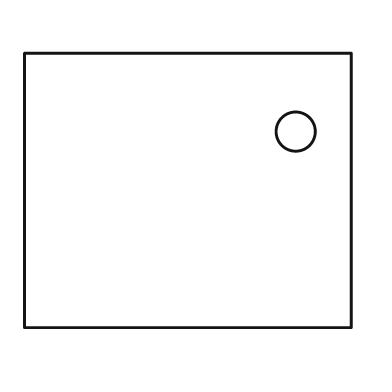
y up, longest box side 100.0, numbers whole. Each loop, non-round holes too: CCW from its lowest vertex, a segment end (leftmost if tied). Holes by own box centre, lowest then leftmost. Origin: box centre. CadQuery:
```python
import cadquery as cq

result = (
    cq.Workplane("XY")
    .moveTo(-50.0, -42.0)
    .lineTo(50.0, -42.0)
    .lineTo(50.0, 42.0)
    .lineTo(-50.0, 42.0)
    .close()
    .moveTo(33.0, 18.0)
    .circle(6.0)
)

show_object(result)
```